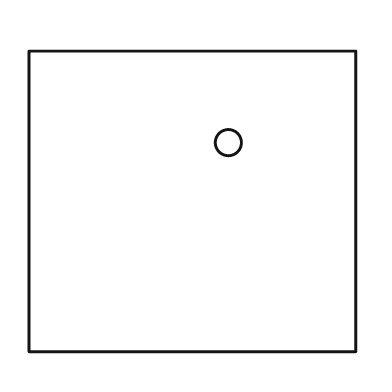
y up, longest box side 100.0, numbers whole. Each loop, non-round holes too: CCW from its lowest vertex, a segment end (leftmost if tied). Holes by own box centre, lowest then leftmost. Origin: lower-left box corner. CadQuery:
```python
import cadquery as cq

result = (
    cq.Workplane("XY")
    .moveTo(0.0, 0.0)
    .lineTo(100.0, 0.0)
    .lineTo(100.0, 92.0)
    .lineTo(0.0, 92.0)
    .close()
    .moveTo(61.0, 64.0)
    .circle(4.0)
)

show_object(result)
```